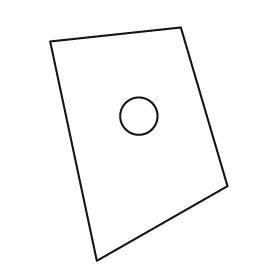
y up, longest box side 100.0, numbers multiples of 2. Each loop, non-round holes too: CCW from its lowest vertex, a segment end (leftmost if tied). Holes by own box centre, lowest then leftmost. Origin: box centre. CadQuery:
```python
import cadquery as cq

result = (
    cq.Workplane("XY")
    .moveTo(-18.0, -50.0)
    .lineTo(38.0, -18.0)
    .lineTo(18.0, 50.0)
    .lineTo(-38.0, 44.0)
    .close()
    .moveTo(0.0, 12.0)
    .circle(8.0)
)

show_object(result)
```